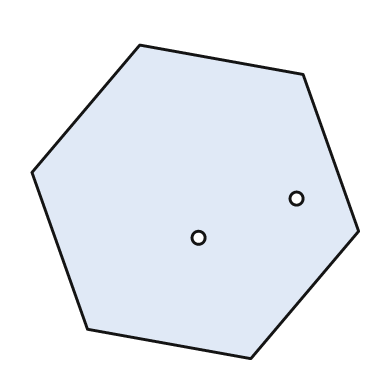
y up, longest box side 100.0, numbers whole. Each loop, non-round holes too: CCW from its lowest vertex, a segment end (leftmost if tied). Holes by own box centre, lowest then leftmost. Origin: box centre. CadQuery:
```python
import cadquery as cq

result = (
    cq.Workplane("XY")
    .moveTo(17.0, -48.0)
    .lineTo(50.0, -9.0)
    .lineTo(33.0, 39.0)
    .lineTo(-17.0, 48.0)
    .lineTo(-50.0, 9.0)
    .lineTo(-33.0, -39.0)
    .close()
    .moveTo(1.0, -11.0)
    .circle(2.0)
    .moveTo(31.0, 1.0)
    .circle(2.0)
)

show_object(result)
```